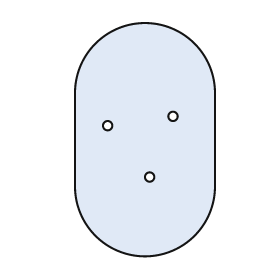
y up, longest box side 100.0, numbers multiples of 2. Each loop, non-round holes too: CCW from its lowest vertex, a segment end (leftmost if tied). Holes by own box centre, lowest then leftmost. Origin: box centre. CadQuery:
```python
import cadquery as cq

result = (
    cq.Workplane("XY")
    .moveTo(-30.0, -20.0)
    .threePointArc((0.0, -50.0), (30.0, -20.0))
    .lineTo(30.0, 20.0)
    .threePointArc((0.0, 50.0), (-30.0, 20.0))
    .close()
    .moveTo(2.0, -16.0)
    .circle(2.0)
    .moveTo(-16.0, 6.0)
    .circle(2.0)
    .moveTo(12.0, 10.0)
    .circle(2.0)
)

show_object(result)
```